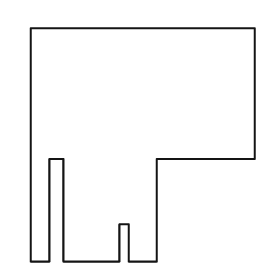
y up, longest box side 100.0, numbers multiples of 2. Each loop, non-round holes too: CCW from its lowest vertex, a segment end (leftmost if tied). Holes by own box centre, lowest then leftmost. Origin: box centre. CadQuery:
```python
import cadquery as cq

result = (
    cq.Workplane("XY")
    .moveTo(-48.0, -50.0)
    .lineTo(-40.0, -50.0)
    .lineTo(-40.0, -6.0)
    .lineTo(-34.0, -6.0)
    .lineTo(-34.0, -50.0)
    .lineTo(-10.0, -50.0)
    .lineTo(-10.0, -34.0)
    .lineTo(-6.0, -34.0)
    .lineTo(-6.0, -50.0)
    .lineTo(6.0, -50.0)
    .lineTo(6.0, -6.0)
    .lineTo(48.0, -6.0)
    .lineTo(48.0, 50.0)
    .lineTo(-48.0, 50.0)
    .close()
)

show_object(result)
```